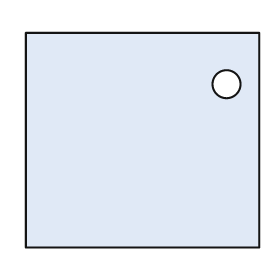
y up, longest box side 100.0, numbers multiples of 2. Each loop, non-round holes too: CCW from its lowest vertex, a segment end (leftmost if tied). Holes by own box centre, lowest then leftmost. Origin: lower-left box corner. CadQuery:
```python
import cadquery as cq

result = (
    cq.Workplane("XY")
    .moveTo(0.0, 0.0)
    .lineTo(100.0, 0.0)
    .lineTo(100.0, 92.0)
    .lineTo(0.0, 92.0)
    .close()
    .moveTo(86.0, 70.0)
    .circle(6.0)
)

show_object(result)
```